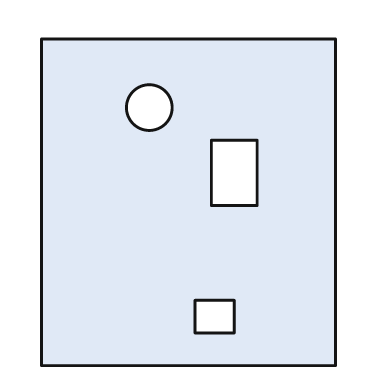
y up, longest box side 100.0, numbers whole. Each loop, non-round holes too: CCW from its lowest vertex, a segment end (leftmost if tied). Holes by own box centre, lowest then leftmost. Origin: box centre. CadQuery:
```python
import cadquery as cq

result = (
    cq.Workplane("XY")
    .moveTo(-45.0, -50.0)
    .lineTo(45.0, -50.0)
    .lineTo(45.0, 50.0)
    .lineTo(-45.0, 50.0)
    .close()
    .moveTo(2.0, -40.0)
    .lineTo(14.0, -40.0)
    .lineTo(14.0, -30.0)
    .lineTo(2.0, -30.0)
    .close()
    .moveTo(7.0, -1.0)
    .lineTo(21.0, -1.0)
    .lineTo(21.0, 19.0)
    .lineTo(7.0, 19.0)
    .close()
    .moveTo(-12.0, 29.0)
    .circle(7.0)
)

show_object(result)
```